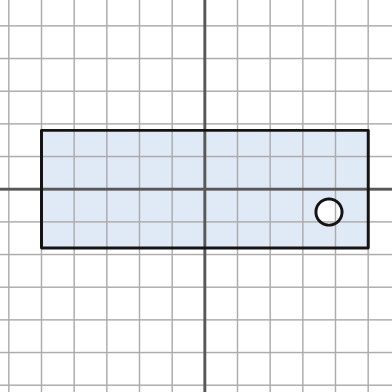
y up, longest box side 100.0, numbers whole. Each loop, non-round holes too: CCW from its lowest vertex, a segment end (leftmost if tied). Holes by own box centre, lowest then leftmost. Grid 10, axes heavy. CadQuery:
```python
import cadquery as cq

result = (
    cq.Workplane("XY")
    .moveTo(-50.0, -18.0)
    .lineTo(50.0, -18.0)
    .lineTo(50.0, 18.0)
    .lineTo(-50.0, 18.0)
    .close()
    .moveTo(38.0, -7.0)
    .circle(4.0)
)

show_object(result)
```